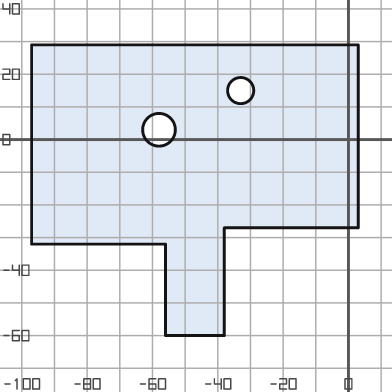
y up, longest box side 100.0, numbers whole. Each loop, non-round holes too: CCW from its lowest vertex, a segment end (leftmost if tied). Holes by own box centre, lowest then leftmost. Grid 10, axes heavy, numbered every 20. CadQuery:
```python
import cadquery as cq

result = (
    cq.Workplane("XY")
    .moveTo(-56.0, -60.0)
    .lineTo(-38.0, -60.0)
    .lineTo(-38.0, -27.0)
    .lineTo(3.0, -27.0)
    .lineTo(3.0, 29.0)
    .lineTo(-97.0, 29.0)
    .lineTo(-97.0, -32.0)
    .lineTo(-56.0, -32.0)
    .close()
    .moveTo(-58.0, 3.0)
    .circle(5.0)
    .moveTo(-33.0, 15.0)
    .circle(4.0)
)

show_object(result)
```